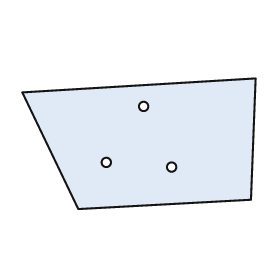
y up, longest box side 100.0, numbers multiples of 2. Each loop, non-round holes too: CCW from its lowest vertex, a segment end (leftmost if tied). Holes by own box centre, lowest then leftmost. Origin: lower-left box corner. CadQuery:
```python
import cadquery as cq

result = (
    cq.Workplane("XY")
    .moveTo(24.0, 0.0)
    .lineTo(98.0, 4.0)
    .lineTo(100.0, 56.0)
    .lineTo(0.0, 50.0)
    .close()
    .moveTo(64.0, 18.0)
    .circle(2.0)
    .moveTo(36.0, 20.0)
    .circle(2.0)
    .moveTo(52.0, 44.0)
    .circle(2.0)
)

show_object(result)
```